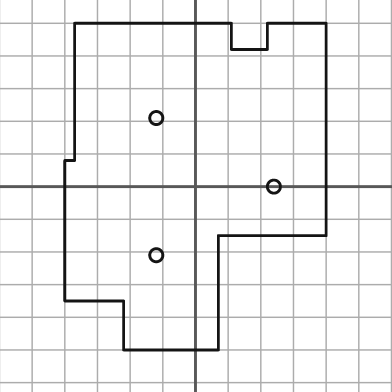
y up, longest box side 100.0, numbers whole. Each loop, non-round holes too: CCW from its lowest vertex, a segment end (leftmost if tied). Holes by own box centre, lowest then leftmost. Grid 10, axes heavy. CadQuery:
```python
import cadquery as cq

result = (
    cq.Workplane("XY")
    .moveTo(-22.0, -50.0)
    .lineTo(7.0, -50.0)
    .lineTo(7.0, -15.0)
    .lineTo(40.0, -15.0)
    .lineTo(40.0, 50.0)
    .lineTo(22.0, 50.0)
    .lineTo(22.0, 42.0)
    .lineTo(11.0, 42.0)
    .lineTo(11.0, 50.0)
    .lineTo(-37.0, 50.0)
    .lineTo(-37.0, 8.0)
    .lineTo(-40.0, 8.0)
    .lineTo(-40.0, -35.0)
    .lineTo(-22.0, -35.0)
    .close()
    .moveTo(-12.0, -21.0)
    .circle(2.0)
    .moveTo(24.0, 0.0)
    .circle(2.0)
    .moveTo(-12.0, 21.0)
    .circle(2.0)
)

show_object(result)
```